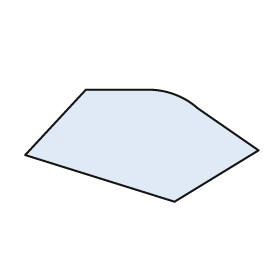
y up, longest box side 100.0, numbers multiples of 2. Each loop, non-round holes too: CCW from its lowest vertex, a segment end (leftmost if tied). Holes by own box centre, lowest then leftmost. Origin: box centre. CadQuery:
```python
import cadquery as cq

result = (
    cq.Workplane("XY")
    .moveTo(14.0, -24.0)
    .lineTo(50.0, -2.0)
    .lineTo(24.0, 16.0)
    .threePointArc((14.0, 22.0), (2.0, 24.0))
    .lineTo(-24.0, 24.0)
    .lineTo(-50.0, -4.0)
    .close()
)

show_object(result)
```